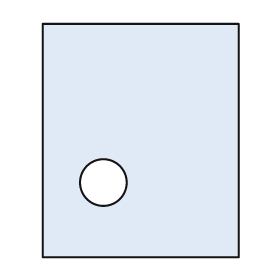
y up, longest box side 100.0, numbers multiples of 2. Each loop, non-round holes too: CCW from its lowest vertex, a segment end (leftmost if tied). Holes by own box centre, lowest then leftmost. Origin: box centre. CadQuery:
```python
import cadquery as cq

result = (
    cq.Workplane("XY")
    .moveTo(-42.0, -50.0)
    .lineTo(42.0, -50.0)
    .lineTo(42.0, 50.0)
    .lineTo(-42.0, 50.0)
    .close()
    .moveTo(-16.0, -18.0)
    .circle(10.0)
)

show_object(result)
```